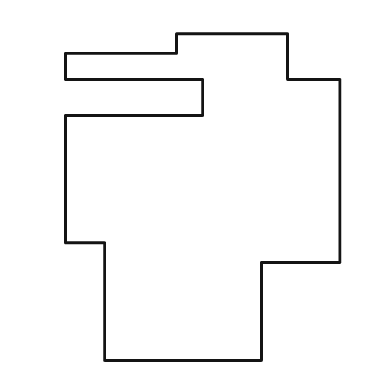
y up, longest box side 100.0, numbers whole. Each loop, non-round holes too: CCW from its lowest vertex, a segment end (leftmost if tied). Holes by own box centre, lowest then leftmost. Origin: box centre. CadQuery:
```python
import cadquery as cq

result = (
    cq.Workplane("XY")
    .moveTo(-30.0, -50.0)
    .lineTo(18.0, -50.0)
    .lineTo(18.0, -20.0)
    .lineTo(42.0, -20.0)
    .lineTo(42.0, 36.0)
    .lineTo(26.0, 36.0)
    .lineTo(26.0, 50.0)
    .lineTo(-8.0, 50.0)
    .lineTo(-8.0, 44.0)
    .lineTo(-42.0, 44.0)
    .lineTo(-42.0, 36.0)
    .lineTo(0.0, 36.0)
    .lineTo(0.0, 25.0)
    .lineTo(-42.0, 25.0)
    .lineTo(-42.0, -14.0)
    .lineTo(-30.0, -14.0)
    .close()
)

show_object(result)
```